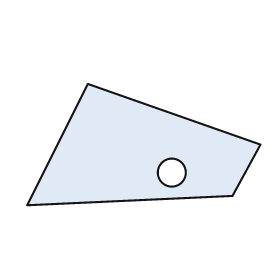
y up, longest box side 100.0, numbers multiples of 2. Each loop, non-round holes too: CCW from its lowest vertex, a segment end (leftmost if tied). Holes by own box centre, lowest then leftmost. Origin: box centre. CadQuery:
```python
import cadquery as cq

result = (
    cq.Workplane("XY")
    .moveTo(-50.0, -26.0)
    .lineTo(38.0, -22.0)
    .lineTo(50.0, 0.0)
    .lineTo(-24.0, 26.0)
    .close()
    .moveTo(12.0, -12.0)
    .circle(6.0)
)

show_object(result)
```